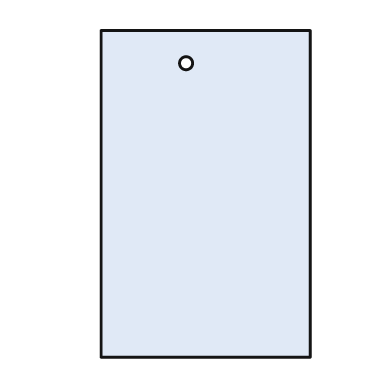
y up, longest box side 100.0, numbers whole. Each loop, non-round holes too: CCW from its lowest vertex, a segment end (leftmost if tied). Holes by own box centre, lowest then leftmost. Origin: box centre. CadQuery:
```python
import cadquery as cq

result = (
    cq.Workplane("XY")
    .moveTo(-32.0, -50.0)
    .lineTo(32.0, -50.0)
    .lineTo(32.0, 50.0)
    .lineTo(-32.0, 50.0)
    .close()
    .moveTo(-6.0, 40.0)
    .circle(2.0)
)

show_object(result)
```